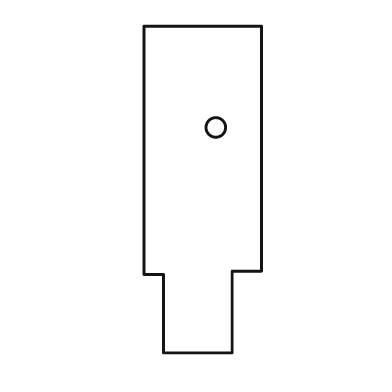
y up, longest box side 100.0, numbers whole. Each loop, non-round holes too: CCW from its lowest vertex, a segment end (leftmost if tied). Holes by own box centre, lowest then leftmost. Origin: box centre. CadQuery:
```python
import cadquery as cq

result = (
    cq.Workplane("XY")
    .moveTo(-12.0, -50.0)
    .lineTo(9.0, -50.0)
    .lineTo(9.0, -25.0)
    .lineTo(18.0, -25.0)
    .lineTo(18.0, 50.0)
    .lineTo(-18.0, 50.0)
    .lineTo(-18.0, -26.0)
    .lineTo(-12.0, -26.0)
    .close()
    .moveTo(4.0, 19.0)
    .circle(3.0)
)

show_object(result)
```